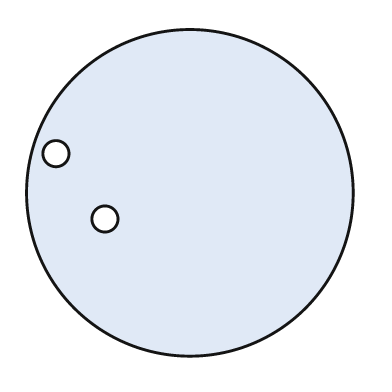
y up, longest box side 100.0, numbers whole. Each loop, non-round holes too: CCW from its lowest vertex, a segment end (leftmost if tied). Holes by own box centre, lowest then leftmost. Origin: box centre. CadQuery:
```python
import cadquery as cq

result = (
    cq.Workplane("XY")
    .moveTo(0.0, 0.0)
    .circle(50.0)
    .moveTo(-26.0, -8.0)
    .circle(4.0)
    .moveTo(-41.0, 12.0)
    .circle(4.0)
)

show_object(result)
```